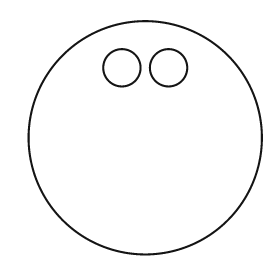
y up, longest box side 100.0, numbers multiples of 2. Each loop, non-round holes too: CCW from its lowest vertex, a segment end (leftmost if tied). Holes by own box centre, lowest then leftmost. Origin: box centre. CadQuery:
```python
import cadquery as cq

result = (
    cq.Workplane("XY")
    .moveTo(0.0, 0.0)
    .circle(50.0)
    .moveTo(-10.0, 30.0)
    .circle(8.0)
    .moveTo(10.0, 30.0)
    .circle(8.0)
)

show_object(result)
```